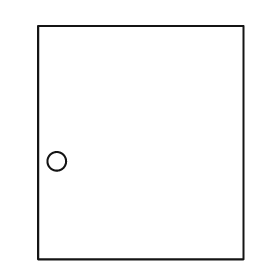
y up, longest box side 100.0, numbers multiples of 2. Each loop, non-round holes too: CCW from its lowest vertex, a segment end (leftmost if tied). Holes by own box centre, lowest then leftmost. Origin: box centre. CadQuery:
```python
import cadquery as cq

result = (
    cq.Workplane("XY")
    .moveTo(-44.0, -50.0)
    .lineTo(44.0, -50.0)
    .lineTo(44.0, 50.0)
    .lineTo(-44.0, 50.0)
    .close()
    .moveTo(-36.0, -8.0)
    .circle(4.0)
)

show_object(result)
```